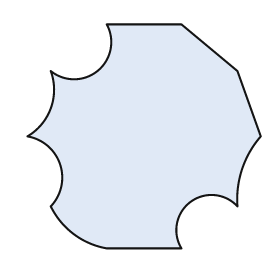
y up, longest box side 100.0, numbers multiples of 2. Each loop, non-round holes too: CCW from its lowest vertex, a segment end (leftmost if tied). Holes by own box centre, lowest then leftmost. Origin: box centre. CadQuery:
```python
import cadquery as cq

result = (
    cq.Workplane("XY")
    .moveTo(-16.0, -48.0)
    .lineTo(16.0, -48.0)
    .threePointArc((20.0, -28.0), (40.0, -30.0))
    .threePointArc((42.0, -14.0), (50.0, 0.0))
    .lineTo(40.0, 28.0)
    .lineTo(16.0, 48.0)
    .lineTo(-16.0, 48.0)
    .threePointArc((-20.0, 28.0), (-40.0, 28.0))
    .threePointArc((-40.0, 12.0), (-50.0, 0.0))
    .threePointArc((-36.0, -12.0), (-40.0, -30.0))
    .threePointArc((-30.0, -42.0), (-16.0, -48.0))
    .close()
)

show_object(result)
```